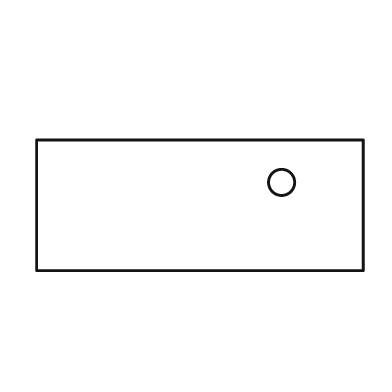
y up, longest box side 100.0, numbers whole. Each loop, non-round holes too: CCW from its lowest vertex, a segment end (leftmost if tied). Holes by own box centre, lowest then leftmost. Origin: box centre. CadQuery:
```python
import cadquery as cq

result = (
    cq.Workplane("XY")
    .moveTo(-50.0, -20.0)
    .lineTo(50.0, -20.0)
    .lineTo(50.0, 20.0)
    .lineTo(-50.0, 20.0)
    .close()
    .moveTo(25.0, 7.0)
    .circle(4.0)
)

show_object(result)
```